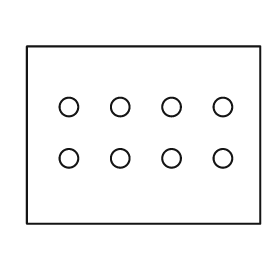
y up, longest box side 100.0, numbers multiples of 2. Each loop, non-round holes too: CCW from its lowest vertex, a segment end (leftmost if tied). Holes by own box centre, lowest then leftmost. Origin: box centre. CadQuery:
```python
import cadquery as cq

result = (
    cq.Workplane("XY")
    .moveTo(-50.0, -38.0)
    .lineTo(50.0, -38.0)
    .lineTo(50.0, 38.0)
    .lineTo(-50.0, 38.0)
    .close()
    .moveTo(-32.0, -10.0)
    .circle(4.0)
    .moveTo(-10.0, -10.0)
    .circle(4.0)
    .moveTo(12.0, -10.0)
    .circle(4.0)
    .moveTo(34.0, -10.0)
    .circle(4.0)
    .moveTo(-32.0, 12.0)
    .circle(4.0)
    .moveTo(-10.0, 12.0)
    .circle(4.0)
    .moveTo(12.0, 12.0)
    .circle(4.0)
    .moveTo(34.0, 12.0)
    .circle(4.0)
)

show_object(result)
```